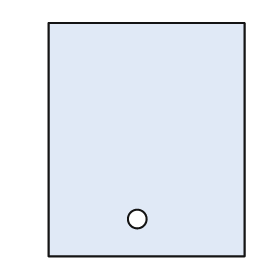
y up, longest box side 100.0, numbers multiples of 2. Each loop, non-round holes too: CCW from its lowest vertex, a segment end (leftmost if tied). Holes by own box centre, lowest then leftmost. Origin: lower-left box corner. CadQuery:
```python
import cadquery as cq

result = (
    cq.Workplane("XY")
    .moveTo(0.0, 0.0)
    .lineTo(84.0, 0.0)
    .lineTo(84.0, 100.0)
    .lineTo(0.0, 100.0)
    .close()
    .moveTo(38.0, 16.0)
    .circle(4.0)
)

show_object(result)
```